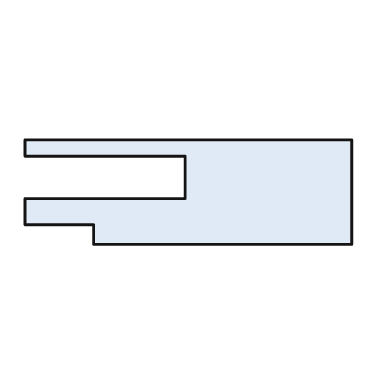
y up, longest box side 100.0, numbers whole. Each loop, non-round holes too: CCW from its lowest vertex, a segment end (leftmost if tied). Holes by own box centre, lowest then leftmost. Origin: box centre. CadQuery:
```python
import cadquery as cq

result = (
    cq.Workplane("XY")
    .moveTo(-29.0, -16.0)
    .lineTo(50.0, -16.0)
    .lineTo(50.0, 16.0)
    .lineTo(-50.0, 16.0)
    .lineTo(-50.0, 11.0)
    .lineTo(-1.0, 11.0)
    .lineTo(-1.0, -2.0)
    .lineTo(-50.0, -2.0)
    .lineTo(-50.0, -10.0)
    .lineTo(-29.0, -10.0)
    .close()
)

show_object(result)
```